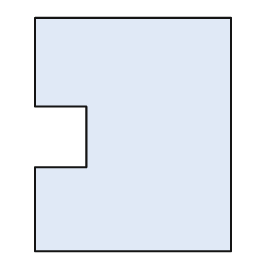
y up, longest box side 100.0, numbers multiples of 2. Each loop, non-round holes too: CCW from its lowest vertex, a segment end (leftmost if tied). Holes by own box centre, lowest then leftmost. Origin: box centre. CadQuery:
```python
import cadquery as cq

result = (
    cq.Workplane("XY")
    .moveTo(-42.0, -50.0)
    .lineTo(42.0, -50.0)
    .lineTo(42.0, 50.0)
    .lineTo(-42.0, 50.0)
    .lineTo(-42.0, 12.0)
    .lineTo(-20.0, 12.0)
    .lineTo(-20.0, -14.0)
    .lineTo(-42.0, -14.0)
    .close()
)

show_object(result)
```